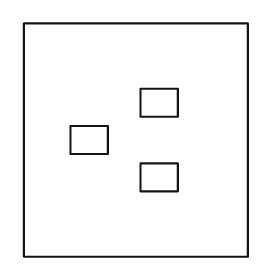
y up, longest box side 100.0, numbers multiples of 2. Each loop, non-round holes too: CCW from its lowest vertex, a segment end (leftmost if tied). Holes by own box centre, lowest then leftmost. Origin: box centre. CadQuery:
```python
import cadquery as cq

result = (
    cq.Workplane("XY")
    .moveTo(-48.0, -50.0)
    .lineTo(48.0, -50.0)
    .lineTo(48.0, 50.0)
    .lineTo(-48.0, 50.0)
    .close()
    .moveTo(2.0, -22.0)
    .lineTo(18.0, -22.0)
    .lineTo(18.0, -10.0)
    .lineTo(2.0, -10.0)
    .close()
    .moveTo(-28.0, -6.0)
    .lineTo(-12.0, -6.0)
    .lineTo(-12.0, 6.0)
    .lineTo(-28.0, 6.0)
    .close()
    .moveTo(2.0, 10.0)
    .lineTo(18.0, 10.0)
    .lineTo(18.0, 22.0)
    .lineTo(2.0, 22.0)
    .close()
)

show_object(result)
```